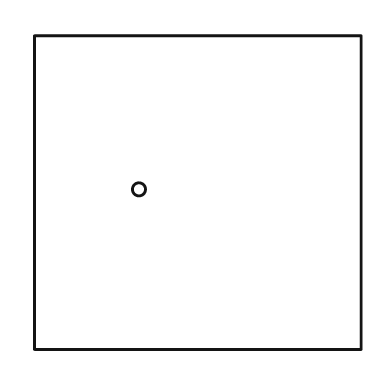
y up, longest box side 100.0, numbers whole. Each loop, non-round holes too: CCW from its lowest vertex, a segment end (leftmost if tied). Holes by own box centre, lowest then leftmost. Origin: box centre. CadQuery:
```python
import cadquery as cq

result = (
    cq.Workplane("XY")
    .moveTo(-50.0, -48.0)
    .lineTo(50.0, -48.0)
    .lineTo(50.0, 48.0)
    .lineTo(-50.0, 48.0)
    .close()
    .moveTo(-18.0, 1.0)
    .circle(2.0)
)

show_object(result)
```